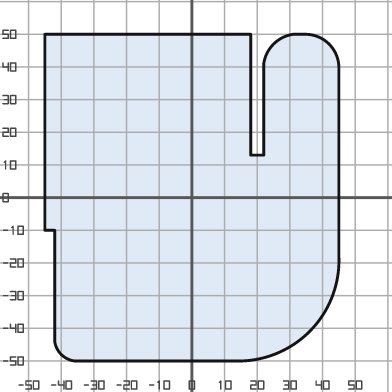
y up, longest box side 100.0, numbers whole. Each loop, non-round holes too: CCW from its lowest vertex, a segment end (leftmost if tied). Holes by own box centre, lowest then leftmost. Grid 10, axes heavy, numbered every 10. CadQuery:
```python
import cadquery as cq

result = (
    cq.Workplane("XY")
    .moveTo(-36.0, -50.0)
    .lineTo(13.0, -50.0)
    .threePointArc((36.0, -41.0), (45.0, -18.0))
    .lineTo(45.0, 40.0)
    .threePointArc((42.0, 47.0), (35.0, 50.0))
    .lineTo(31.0, 50.0)
    .threePointArc((25.0, 47.0), (22.0, 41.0))
    .lineTo(22.0, 13.0)
    .lineTo(18.0, 13.0)
    .lineTo(18.0, 50.0)
    .lineTo(-45.0, 50.0)
    .lineTo(-45.0, -10.0)
    .lineTo(-42.0, -10.0)
    .lineTo(-42.0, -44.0)
    .threePointArc((-40.0, -48.0), (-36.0, -50.0))
    .close()
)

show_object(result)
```